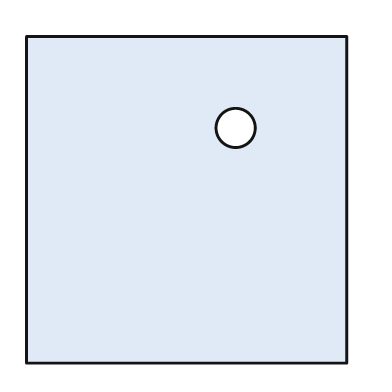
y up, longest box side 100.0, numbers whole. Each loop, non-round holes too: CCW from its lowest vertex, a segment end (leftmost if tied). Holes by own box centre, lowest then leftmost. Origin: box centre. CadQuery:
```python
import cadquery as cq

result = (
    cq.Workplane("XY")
    .moveTo(-49.0, -50.0)
    .lineTo(49.0, -50.0)
    .lineTo(49.0, 50.0)
    .lineTo(-49.0, 50.0)
    .close()
    .moveTo(15.0, 22.0)
    .circle(6.0)
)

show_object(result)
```